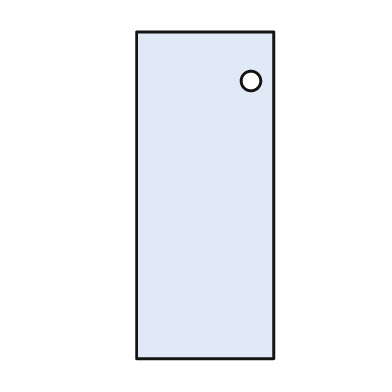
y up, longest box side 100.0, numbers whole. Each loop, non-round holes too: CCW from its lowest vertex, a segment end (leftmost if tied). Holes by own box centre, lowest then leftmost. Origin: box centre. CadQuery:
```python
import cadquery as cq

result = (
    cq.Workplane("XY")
    .moveTo(-21.0, -50.0)
    .lineTo(21.0, -50.0)
    .lineTo(21.0, 50.0)
    .lineTo(-21.0, 50.0)
    .close()
    .moveTo(14.0, 35.0)
    .circle(3.0)
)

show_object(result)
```